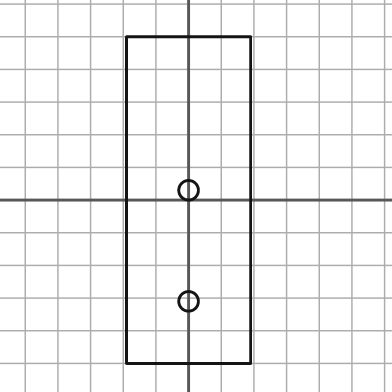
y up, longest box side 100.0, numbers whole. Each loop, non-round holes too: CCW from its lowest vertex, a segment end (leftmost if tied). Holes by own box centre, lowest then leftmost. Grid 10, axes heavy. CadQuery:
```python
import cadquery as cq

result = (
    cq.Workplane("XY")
    .moveTo(-19.0, -50.0)
    .lineTo(19.0, -50.0)
    .lineTo(19.0, 50.0)
    .lineTo(-19.0, 50.0)
    .close()
    .moveTo(0.0, -31.0)
    .circle(3.0)
    .moveTo(0.0, 3.0)
    .circle(3.0)
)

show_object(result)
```